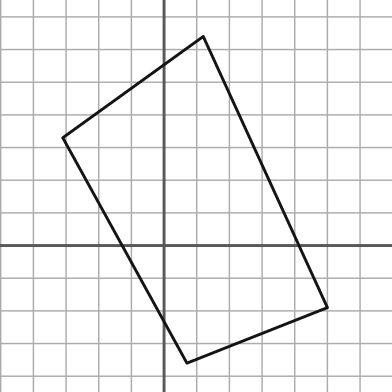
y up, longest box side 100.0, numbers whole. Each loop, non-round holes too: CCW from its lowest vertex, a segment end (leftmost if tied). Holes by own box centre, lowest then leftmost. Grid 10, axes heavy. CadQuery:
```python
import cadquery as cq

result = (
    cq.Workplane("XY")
    .moveTo(7.0, -36.0)
    .lineTo(50.0, -19.0)
    .lineTo(12.0, 64.0)
    .lineTo(-31.0, 33.0)
    .close()
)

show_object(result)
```